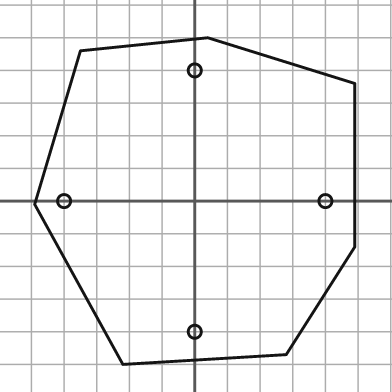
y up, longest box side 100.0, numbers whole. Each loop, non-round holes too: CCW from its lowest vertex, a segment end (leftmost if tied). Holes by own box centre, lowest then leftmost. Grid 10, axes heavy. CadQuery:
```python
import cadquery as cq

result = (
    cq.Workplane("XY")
    .moveTo(-22.0, -50.0)
    .lineTo(28.0, -47.0)
    .lineTo(49.0, -14.0)
    .lineTo(49.0, 36.0)
    .lineTo(4.0, 50.0)
    .lineTo(-35.0, 46.0)
    .lineTo(-49.0, -1.0)
    .close()
    .moveTo(0.0, -40.0)
    .circle(2.0)
    .moveTo(-40.0, 0.0)
    .circle(2.0)
    .moveTo(40.0, 0.0)
    .circle(2.0)
    .moveTo(0.0, 40.0)
    .circle(2.0)
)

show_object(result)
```